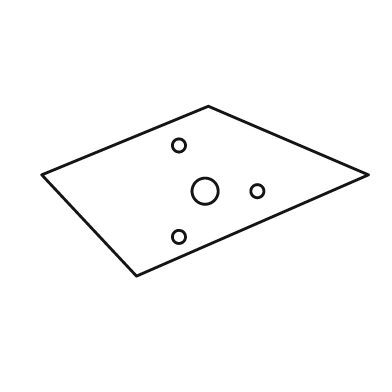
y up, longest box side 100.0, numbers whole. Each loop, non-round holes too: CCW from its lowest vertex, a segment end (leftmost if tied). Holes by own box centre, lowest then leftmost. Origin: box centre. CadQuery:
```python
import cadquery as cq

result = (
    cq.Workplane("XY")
    .moveTo(-21.0, -26.0)
    .lineTo(50.0, 5.0)
    .lineTo(1.0, 26.0)
    .lineTo(-50.0, 5.0)
    .close()
    .moveTo(-8.0, -14.0)
    .circle(2.0)
    .moveTo(0.0, 0.0)
    .circle(4.0)
    .moveTo(16.0, 0.0)
    .circle(2.0)
    .moveTo(-8.0, 14.0)
    .circle(2.0)
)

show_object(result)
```